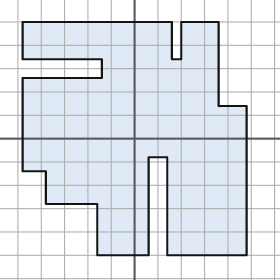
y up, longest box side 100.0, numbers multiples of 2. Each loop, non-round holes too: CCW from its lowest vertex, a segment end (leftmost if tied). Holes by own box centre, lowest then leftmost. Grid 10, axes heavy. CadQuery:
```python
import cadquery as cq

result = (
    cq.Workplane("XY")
    .moveTo(-16.0, -50.0)
    .lineTo(6.0, -50.0)
    .lineTo(6.0, -8.0)
    .lineTo(14.0, -8.0)
    .lineTo(14.0, -50.0)
    .lineTo(48.0, -50.0)
    .lineTo(48.0, 14.0)
    .lineTo(36.0, 14.0)
    .lineTo(36.0, 50.0)
    .lineTo(20.0, 50.0)
    .lineTo(20.0, 34.0)
    .lineTo(16.0, 34.0)
    .lineTo(16.0, 50.0)
    .lineTo(-48.0, 50.0)
    .lineTo(-48.0, 34.0)
    .lineTo(-14.0, 34.0)
    .lineTo(-14.0, 26.0)
    .lineTo(-48.0, 26.0)
    .lineTo(-48.0, -14.0)
    .lineTo(-38.0, -14.0)
    .lineTo(-38.0, -28.0)
    .lineTo(-16.0, -28.0)
    .close()
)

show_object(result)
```